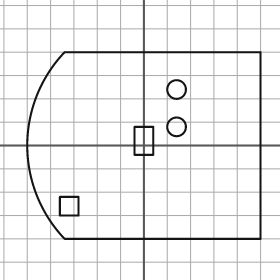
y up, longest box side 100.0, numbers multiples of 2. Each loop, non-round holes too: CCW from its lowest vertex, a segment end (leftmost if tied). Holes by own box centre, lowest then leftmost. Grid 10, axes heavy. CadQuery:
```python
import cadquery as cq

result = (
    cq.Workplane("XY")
    .moveTo(-34.0, -40.0)
    .lineTo(50.0, -40.0)
    .lineTo(50.0, 40.0)
    .lineTo(-34.0, 40.0)
    .threePointArc((-50.0, 0.0), (-34.0, -40.0))
    .close()
    .moveTo(-36.0, -30.0)
    .lineTo(-28.0, -30.0)
    .lineTo(-28.0, -22.0)
    .lineTo(-36.0, -22.0)
    .close()
    .moveTo(-4.0, -4.0)
    .lineTo(4.0, -4.0)
    .lineTo(4.0, 8.0)
    .lineTo(-4.0, 8.0)
    .close()
    .moveTo(14.0, 8.0)
    .circle(4.0)
    .moveTo(14.0, 24.0)
    .circle(4.0)
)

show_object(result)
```